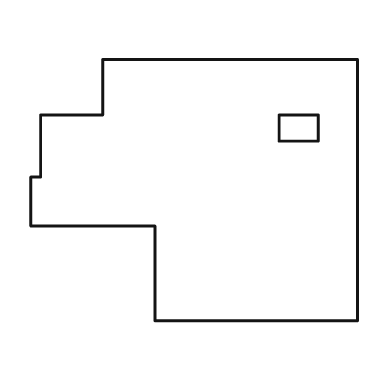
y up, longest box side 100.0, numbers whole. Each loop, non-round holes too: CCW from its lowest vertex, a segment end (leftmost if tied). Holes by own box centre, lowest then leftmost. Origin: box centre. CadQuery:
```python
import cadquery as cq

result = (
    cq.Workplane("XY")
    .moveTo(-12.0, -40.0)
    .lineTo(50.0, -40.0)
    .lineTo(50.0, 40.0)
    .lineTo(-28.0, 40.0)
    .lineTo(-28.0, 23.0)
    .lineTo(-47.0, 23.0)
    .lineTo(-47.0, 4.0)
    .lineTo(-50.0, 4.0)
    .lineTo(-50.0, -11.0)
    .lineTo(-12.0, -11.0)
    .close()
    .moveTo(26.0, 15.0)
    .lineTo(38.0, 15.0)
    .lineTo(38.0, 23.0)
    .lineTo(26.0, 23.0)
    .close()
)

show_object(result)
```